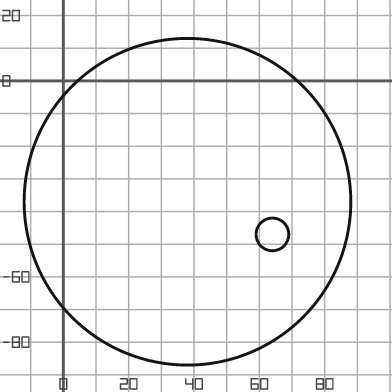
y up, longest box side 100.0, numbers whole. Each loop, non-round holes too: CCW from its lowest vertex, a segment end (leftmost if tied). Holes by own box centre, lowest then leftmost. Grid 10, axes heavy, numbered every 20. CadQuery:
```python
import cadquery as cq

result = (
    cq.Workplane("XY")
    .moveTo(38.0, -37.0)
    .circle(50.0)
    .moveTo(64.0, -47.0)
    .circle(5.0)
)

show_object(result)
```